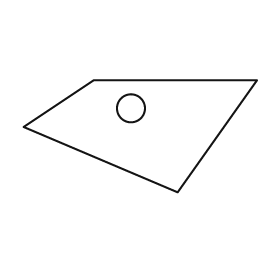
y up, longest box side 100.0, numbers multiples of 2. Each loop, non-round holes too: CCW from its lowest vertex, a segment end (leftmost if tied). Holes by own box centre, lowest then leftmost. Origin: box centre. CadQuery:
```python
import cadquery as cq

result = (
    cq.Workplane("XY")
    .moveTo(16.0, -24.0)
    .lineTo(50.0, 24.0)
    .lineTo(-20.0, 24.0)
    .lineTo(-50.0, 4.0)
    .close()
    .moveTo(-4.0, 12.0)
    .circle(6.0)
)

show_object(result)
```